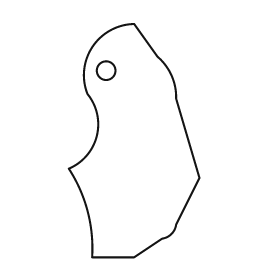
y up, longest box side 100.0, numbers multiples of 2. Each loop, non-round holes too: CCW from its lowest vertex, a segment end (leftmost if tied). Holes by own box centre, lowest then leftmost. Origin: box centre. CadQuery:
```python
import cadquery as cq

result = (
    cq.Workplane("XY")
    .moveTo(-18.0, -50.0)
    .lineTo(0.0, -50.0)
    .lineTo(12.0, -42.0)
    .threePointArc((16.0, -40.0), (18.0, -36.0))
    .lineTo(28.0, -16.0)
    .lineTo(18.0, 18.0)
    .threePointArc((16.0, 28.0), (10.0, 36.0))
    .lineTo(0.0, 50.0)
    .threePointArc((-18.0, 40.0), (-20.0, 20.0))
    .threePointArc((-16.0, 2.0), (-28.0, -12.0))
    .threePointArc((-20.0, -30.0), (-18.0, -50.0))
    .close()
    .moveTo(-12.0, 30.0)
    .circle(4.0)
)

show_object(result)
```